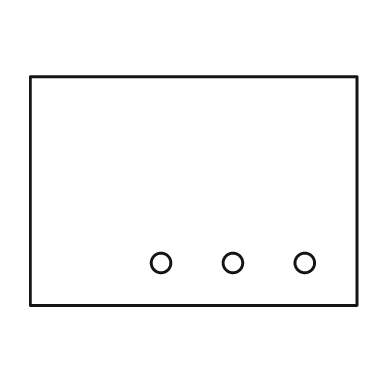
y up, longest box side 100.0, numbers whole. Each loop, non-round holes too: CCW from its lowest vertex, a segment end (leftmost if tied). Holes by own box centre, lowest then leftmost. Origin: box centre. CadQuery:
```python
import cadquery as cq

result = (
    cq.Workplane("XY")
    .moveTo(-50.0, -35.0)
    .lineTo(50.0, -35.0)
    .lineTo(50.0, 35.0)
    .lineTo(-50.0, 35.0)
    .close()
    .moveTo(-10.0, -22.0)
    .circle(3.0)
    .moveTo(12.0, -22.0)
    .circle(3.0)
    .moveTo(34.0, -22.0)
    .circle(3.0)
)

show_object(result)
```